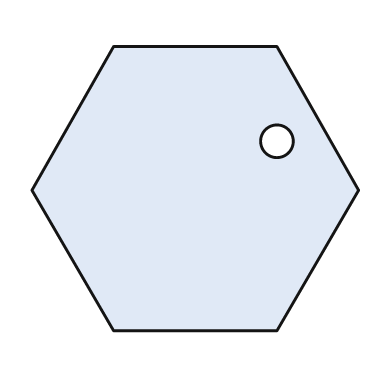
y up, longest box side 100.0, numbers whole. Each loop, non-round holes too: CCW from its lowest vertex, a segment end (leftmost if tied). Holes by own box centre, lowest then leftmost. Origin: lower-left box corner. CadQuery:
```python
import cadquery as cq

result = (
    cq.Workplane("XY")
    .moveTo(25.0, 0.0)
    .lineTo(75.0, 0.0)
    .lineTo(100.0, 43.0)
    .lineTo(75.0, 87.0)
    .lineTo(25.0, 87.0)
    .lineTo(0.0, 43.0)
    .close()
    .moveTo(75.0, 58.0)
    .circle(5.0)
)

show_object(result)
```